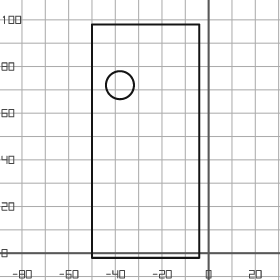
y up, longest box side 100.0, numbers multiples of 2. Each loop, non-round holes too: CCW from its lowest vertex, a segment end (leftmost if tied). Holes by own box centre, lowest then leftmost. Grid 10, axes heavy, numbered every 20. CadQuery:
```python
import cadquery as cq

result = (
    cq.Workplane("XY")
    .moveTo(-50.0, -2.0)
    .lineTo(-4.0, -2.0)
    .lineTo(-4.0, 98.0)
    .lineTo(-50.0, 98.0)
    .close()
    .moveTo(-38.0, 72.0)
    .circle(6.0)
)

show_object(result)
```